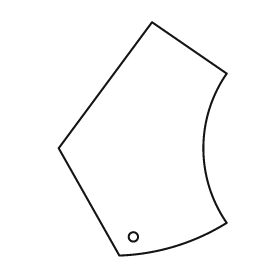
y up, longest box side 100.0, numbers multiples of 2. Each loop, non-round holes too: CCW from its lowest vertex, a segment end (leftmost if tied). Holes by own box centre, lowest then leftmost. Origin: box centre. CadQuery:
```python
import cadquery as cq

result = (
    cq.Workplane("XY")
    .moveTo(-10.0, -50.0)
    .threePointArc((14.0, -46.0), (36.0, -36.0))
    .threePointArc((26.0, -4.0), (36.0, 28.0))
    .lineTo(4.0, 50.0)
    .lineTo(-36.0, -4.0)
    .close()
    .moveTo(-4.0, -42.0)
    .circle(2.0)
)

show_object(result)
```